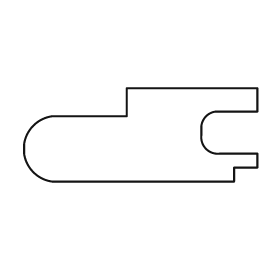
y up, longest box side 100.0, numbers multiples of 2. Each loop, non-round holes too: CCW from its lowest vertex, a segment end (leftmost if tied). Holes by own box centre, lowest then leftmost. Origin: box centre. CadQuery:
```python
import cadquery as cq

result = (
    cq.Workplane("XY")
    .moveTo(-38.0, -20.0)
    .lineTo(40.0, -20.0)
    .lineTo(40.0, -14.0)
    .lineTo(50.0, -14.0)
    .lineTo(50.0, -8.0)
    .lineTo(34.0, -8.0)
    .threePointArc((28.0, -6.0), (26.0, 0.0))
    .lineTo(26.0, 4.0)
    .threePointArc((28.0, 8.0), (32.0, 10.0))
    .lineTo(50.0, 10.0)
    .lineTo(50.0, 20.0)
    .lineTo(-6.0, 20.0)
    .lineTo(-6.0, 8.0)
    .lineTo(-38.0, 8.0)
    .threePointArc((-46.0, 4.0), (-50.0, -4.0))
    .lineTo(-50.0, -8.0)
    .threePointArc((-46.0, -16.0), (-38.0, -20.0))
    .close()
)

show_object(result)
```